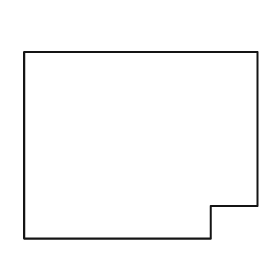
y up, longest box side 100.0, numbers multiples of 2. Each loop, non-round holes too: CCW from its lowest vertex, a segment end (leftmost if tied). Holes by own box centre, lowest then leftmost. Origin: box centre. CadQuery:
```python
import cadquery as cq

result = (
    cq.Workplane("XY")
    .moveTo(-50.0, -40.0)
    .lineTo(30.0, -40.0)
    .lineTo(30.0, -26.0)
    .lineTo(50.0, -26.0)
    .lineTo(50.0, 40.0)
    .lineTo(-50.0, 40.0)
    .close()
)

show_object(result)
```